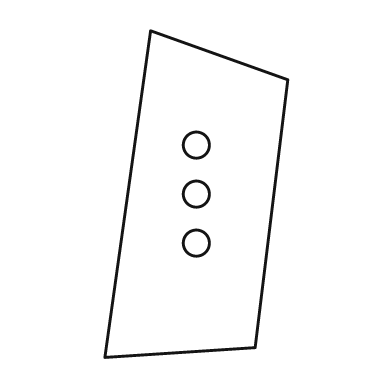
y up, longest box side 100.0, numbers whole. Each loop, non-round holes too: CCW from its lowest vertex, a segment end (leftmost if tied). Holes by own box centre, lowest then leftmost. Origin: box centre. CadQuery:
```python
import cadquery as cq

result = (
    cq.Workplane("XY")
    .moveTo(-28.0, -50.0)
    .lineTo(18.0, -47.0)
    .lineTo(28.0, 35.0)
    .lineTo(-14.0, 50.0)
    .close()
    .moveTo(0.0, -15.0)
    .circle(4.0)
    .moveTo(0.0, 0.0)
    .circle(4.0)
    .moveTo(0.0, 15.0)
    .circle(4.0)
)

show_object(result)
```